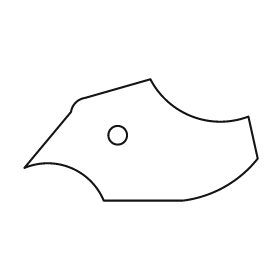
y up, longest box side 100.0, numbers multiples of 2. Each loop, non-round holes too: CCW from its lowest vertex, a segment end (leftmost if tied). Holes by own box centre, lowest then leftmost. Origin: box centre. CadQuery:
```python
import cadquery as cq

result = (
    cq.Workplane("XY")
    .moveTo(-16.0, -26.0)
    .lineTo(18.0, -26.0)
    .threePointArc((36.0, -20.0), (50.0, -8.0))
    .lineTo(46.0, 10.0)
    .threePointArc((22.0, 10.0), (4.0, 26.0))
    .lineTo(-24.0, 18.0)
    .threePointArc((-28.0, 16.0), (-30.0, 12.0))
    .lineTo(-50.0, -12.0)
    .threePointArc((-30.0, -12.0), (-16.0, -26.0))
    .close()
    .moveTo(-10.0, 2.0)
    .circle(4.0)
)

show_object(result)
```